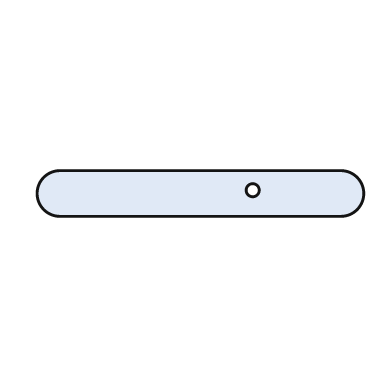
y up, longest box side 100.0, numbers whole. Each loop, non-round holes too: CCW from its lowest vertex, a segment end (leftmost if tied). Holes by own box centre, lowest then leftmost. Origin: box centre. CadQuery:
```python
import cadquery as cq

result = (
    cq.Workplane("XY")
    .moveTo(-43.0, -7.0)
    .lineTo(43.0, -7.0)
    .threePointArc((50.0, 0.0), (43.0, 7.0))
    .lineTo(-43.0, 7.0)
    .threePointArc((-50.0, 0.0), (-43.0, -7.0))
    .close()
    .moveTo(16.0, 1.0)
    .circle(2.0)
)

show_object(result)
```